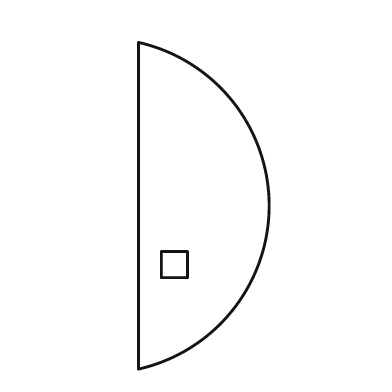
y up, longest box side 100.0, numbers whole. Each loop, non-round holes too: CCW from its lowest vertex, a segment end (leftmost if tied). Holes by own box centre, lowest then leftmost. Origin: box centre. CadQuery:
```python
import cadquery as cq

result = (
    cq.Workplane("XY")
    .moveTo(-20.0, -50.0)
    .threePointArc((20.0, 0.0), (-20.0, 50.0))
    .close()
    .moveTo(-13.0, -22.0)
    .lineTo(-5.0, -22.0)
    .lineTo(-5.0, -14.0)
    .lineTo(-13.0, -14.0)
    .close()
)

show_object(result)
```